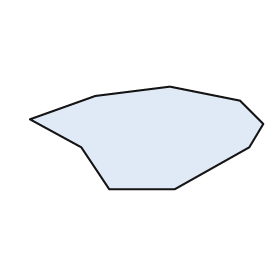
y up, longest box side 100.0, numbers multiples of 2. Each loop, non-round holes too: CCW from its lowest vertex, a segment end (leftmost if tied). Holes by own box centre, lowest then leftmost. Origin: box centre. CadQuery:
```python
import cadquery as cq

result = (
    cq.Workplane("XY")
    .moveTo(-16.0, -22.0)
    .lineTo(12.0, -22.0)
    .lineTo(44.0, -4.0)
    .lineTo(50.0, 6.0)
    .lineTo(40.0, 16.0)
    .lineTo(10.0, 22.0)
    .lineTo(-22.0, 18.0)
    .lineTo(-50.0, 8.0)
    .lineTo(-28.0, -4.0)
    .close()
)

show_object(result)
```